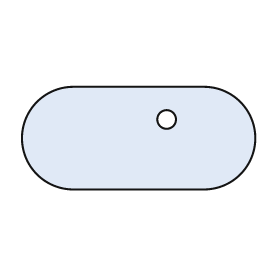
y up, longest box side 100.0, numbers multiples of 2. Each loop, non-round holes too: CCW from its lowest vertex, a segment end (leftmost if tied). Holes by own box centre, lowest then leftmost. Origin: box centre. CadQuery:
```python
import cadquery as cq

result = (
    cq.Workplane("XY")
    .moveTo(-28.0, -22.0)
    .lineTo(28.0, -22.0)
    .threePointArc((50.0, 0.0), (28.0, 22.0))
    .lineTo(-28.0, 22.0)
    .threePointArc((-50.0, 0.0), (-28.0, -22.0))
    .close()
    .moveTo(12.0, 8.0)
    .circle(4.0)
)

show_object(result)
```